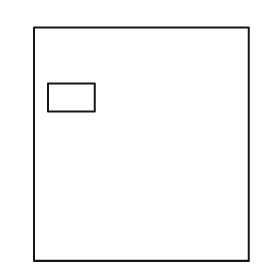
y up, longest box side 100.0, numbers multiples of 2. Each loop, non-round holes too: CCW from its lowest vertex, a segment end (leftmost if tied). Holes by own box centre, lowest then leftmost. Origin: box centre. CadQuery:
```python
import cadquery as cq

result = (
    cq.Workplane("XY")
    .moveTo(-46.0, -50.0)
    .lineTo(46.0, -50.0)
    .lineTo(46.0, 50.0)
    .lineTo(-46.0, 50.0)
    .close()
    .moveTo(-40.0, 14.0)
    .lineTo(-20.0, 14.0)
    .lineTo(-20.0, 26.0)
    .lineTo(-40.0, 26.0)
    .close()
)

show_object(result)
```